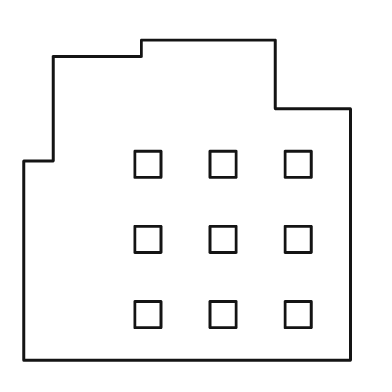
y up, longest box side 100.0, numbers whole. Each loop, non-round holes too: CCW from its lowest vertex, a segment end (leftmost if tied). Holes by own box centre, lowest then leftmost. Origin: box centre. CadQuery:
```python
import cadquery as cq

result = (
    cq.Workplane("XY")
    .moveTo(-50.0, -49.0)
    .lineTo(50.0, -49.0)
    .lineTo(50.0, 28.0)
    .lineTo(27.0, 28.0)
    .lineTo(27.0, 49.0)
    .lineTo(-14.0, 49.0)
    .lineTo(-14.0, 44.0)
    .lineTo(-41.0, 44.0)
    .lineTo(-41.0, 12.0)
    .lineTo(-50.0, 12.0)
    .close()
    .moveTo(-16.0, -39.0)
    .lineTo(-8.0, -39.0)
    .lineTo(-8.0, -31.0)
    .lineTo(-16.0, -31.0)
    .close()
    .moveTo(7.0, -39.0)
    .lineTo(15.0, -39.0)
    .lineTo(15.0, -31.0)
    .lineTo(7.0, -31.0)
    .close()
    .moveTo(30.0, -39.0)
    .lineTo(38.0, -39.0)
    .lineTo(38.0, -31.0)
    .lineTo(30.0, -31.0)
    .close()
    .moveTo(-16.0, -16.0)
    .lineTo(-8.0, -16.0)
    .lineTo(-8.0, -8.0)
    .lineTo(-16.0, -8.0)
    .close()
    .moveTo(7.0, -16.0)
    .lineTo(15.0, -16.0)
    .lineTo(15.0, -8.0)
    .lineTo(7.0, -8.0)
    .close()
    .moveTo(30.0, -16.0)
    .lineTo(38.0, -16.0)
    .lineTo(38.0, -8.0)
    .lineTo(30.0, -8.0)
    .close()
    .moveTo(-16.0, 7.0)
    .lineTo(-8.0, 7.0)
    .lineTo(-8.0, 15.0)
    .lineTo(-16.0, 15.0)
    .close()
    .moveTo(7.0, 7.0)
    .lineTo(15.0, 7.0)
    .lineTo(15.0, 15.0)
    .lineTo(7.0, 15.0)
    .close()
    .moveTo(30.0, 7.0)
    .lineTo(38.0, 7.0)
    .lineTo(38.0, 15.0)
    .lineTo(30.0, 15.0)
    .close()
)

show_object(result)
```